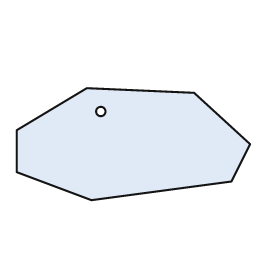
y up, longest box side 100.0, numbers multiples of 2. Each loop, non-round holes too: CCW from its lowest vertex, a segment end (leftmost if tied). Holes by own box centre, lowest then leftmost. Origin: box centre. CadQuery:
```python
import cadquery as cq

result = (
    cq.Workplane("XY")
    .moveTo(-18.0, -24.0)
    .lineTo(42.0, -16.0)
    .lineTo(50.0, 0.0)
    .lineTo(26.0, 22.0)
    .lineTo(-20.0, 24.0)
    .lineTo(-50.0, 6.0)
    .lineTo(-50.0, -12.0)
    .close()
    .moveTo(-14.0, 14.0)
    .circle(2.0)
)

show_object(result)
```